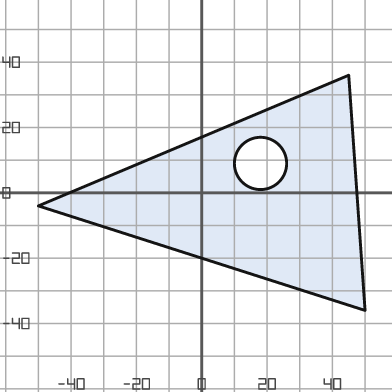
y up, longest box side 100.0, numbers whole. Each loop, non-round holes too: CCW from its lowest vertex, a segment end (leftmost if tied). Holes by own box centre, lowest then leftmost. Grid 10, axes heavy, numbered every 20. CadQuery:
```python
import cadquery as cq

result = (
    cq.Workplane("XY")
    .moveTo(50.0, -36.0)
    .lineTo(45.0, 36.0)
    .lineTo(-50.0, -4.0)
    .close()
    .moveTo(18.0, 9.0)
    .circle(8.0)
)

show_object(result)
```